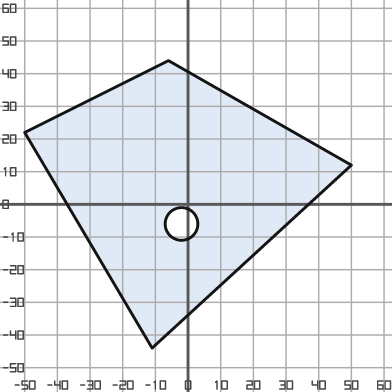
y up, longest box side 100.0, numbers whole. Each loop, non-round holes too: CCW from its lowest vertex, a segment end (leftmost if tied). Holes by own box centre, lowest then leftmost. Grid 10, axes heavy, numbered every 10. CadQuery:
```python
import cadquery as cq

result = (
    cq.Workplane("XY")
    .moveTo(-11.0, -44.0)
    .lineTo(50.0, 12.0)
    .lineTo(-6.0, 44.0)
    .lineTo(-50.0, 22.0)
    .close()
    .moveTo(-2.0, -6.0)
    .circle(5.0)
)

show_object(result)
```